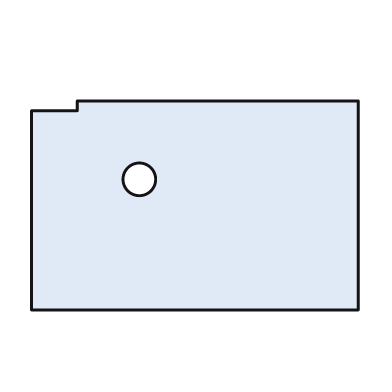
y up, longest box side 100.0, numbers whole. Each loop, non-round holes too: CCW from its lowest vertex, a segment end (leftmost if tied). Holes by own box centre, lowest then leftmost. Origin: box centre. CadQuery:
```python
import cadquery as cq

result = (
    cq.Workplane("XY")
    .moveTo(-50.0, -32.0)
    .lineTo(50.0, -32.0)
    .lineTo(50.0, 32.0)
    .lineTo(-36.0, 32.0)
    .lineTo(-36.0, 29.0)
    .lineTo(-50.0, 29.0)
    .close()
    .moveTo(-17.0, 8.0)
    .circle(5.0)
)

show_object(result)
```